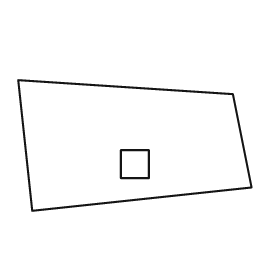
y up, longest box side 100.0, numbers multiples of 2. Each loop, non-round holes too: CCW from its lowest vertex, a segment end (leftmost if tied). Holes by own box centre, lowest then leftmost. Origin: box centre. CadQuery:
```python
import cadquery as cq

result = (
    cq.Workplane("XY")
    .moveTo(-44.0, -28.0)
    .lineTo(50.0, -18.0)
    .lineTo(42.0, 22.0)
    .lineTo(-50.0, 28.0)
    .close()
    .moveTo(-6.0, -14.0)
    .lineTo(6.0, -14.0)
    .lineTo(6.0, -2.0)
    .lineTo(-6.0, -2.0)
    .close()
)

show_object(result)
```